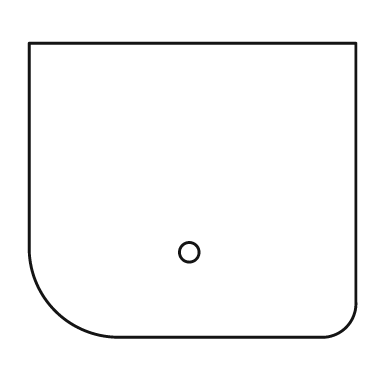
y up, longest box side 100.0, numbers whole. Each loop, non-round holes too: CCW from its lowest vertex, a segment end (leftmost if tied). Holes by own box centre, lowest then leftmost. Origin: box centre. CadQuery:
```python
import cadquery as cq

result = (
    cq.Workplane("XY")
    .moveTo(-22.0, -45.0)
    .lineTo(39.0, -45.0)
    .threePointArc((47.0, -42.0), (50.0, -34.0))
    .lineTo(50.0, 45.0)
    .lineTo(-50.0, 45.0)
    .lineTo(-50.0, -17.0)
    .threePointArc((-42.0, -37.0), (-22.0, -45.0))
    .close()
    .moveTo(-1.0, -19.0)
    .circle(3.0)
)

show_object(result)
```